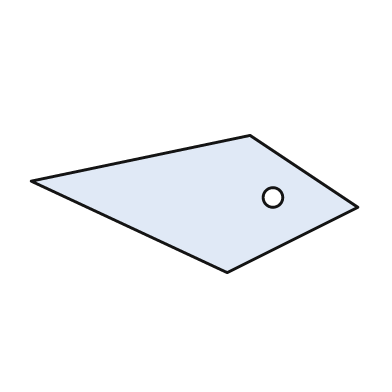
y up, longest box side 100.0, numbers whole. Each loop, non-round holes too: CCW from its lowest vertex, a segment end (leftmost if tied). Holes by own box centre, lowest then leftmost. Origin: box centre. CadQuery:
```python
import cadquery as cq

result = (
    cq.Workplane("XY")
    .moveTo(10.0, -21.0)
    .lineTo(50.0, -1.0)
    .lineTo(17.0, 21.0)
    .lineTo(-50.0, 7.0)
    .close()
    .moveTo(24.0, 2.0)
    .circle(3.0)
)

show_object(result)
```